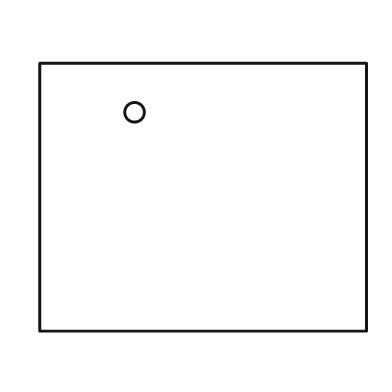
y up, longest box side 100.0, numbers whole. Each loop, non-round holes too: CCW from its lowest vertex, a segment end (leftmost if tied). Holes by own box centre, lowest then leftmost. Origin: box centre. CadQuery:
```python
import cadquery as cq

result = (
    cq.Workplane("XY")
    .moveTo(-50.0, -41.0)
    .lineTo(50.0, -41.0)
    .lineTo(50.0, 41.0)
    .lineTo(-50.0, 41.0)
    .close()
    .moveTo(-21.0, 26.0)
    .circle(3.0)
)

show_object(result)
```